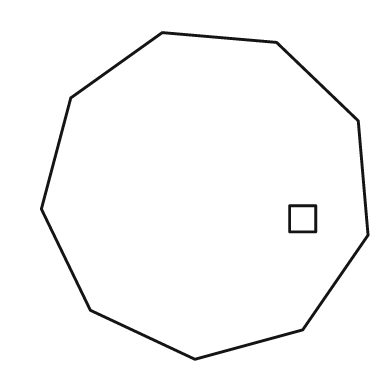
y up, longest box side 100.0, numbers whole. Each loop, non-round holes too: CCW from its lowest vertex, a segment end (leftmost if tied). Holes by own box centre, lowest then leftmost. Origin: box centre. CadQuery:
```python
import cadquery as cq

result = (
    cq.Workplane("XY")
    .moveTo(-3.0, -50.0)
    .lineTo(30.0, -41.0)
    .lineTo(50.0, -12.0)
    .lineTo(47.0, 23.0)
    .lineTo(22.0, 47.0)
    .lineTo(-13.0, 50.0)
    .lineTo(-41.0, 30.0)
    .lineTo(-50.0, -4.0)
    .lineTo(-35.0, -35.0)
    .close()
    .moveTo(26.0, -11.0)
    .lineTo(34.0, -11.0)
    .lineTo(34.0, -3.0)
    .lineTo(26.0, -3.0)
    .close()
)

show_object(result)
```